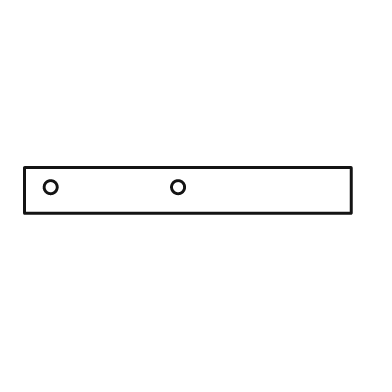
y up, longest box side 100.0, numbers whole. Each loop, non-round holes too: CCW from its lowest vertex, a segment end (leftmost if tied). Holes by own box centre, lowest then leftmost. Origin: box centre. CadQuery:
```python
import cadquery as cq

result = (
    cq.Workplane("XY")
    .moveTo(-50.0, -7.0)
    .lineTo(50.0, -7.0)
    .lineTo(50.0, 7.0)
    .lineTo(-50.0, 7.0)
    .close()
    .moveTo(-42.0, 1.0)
    .circle(2.0)
    .moveTo(-3.0, 1.0)
    .circle(2.0)
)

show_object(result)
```